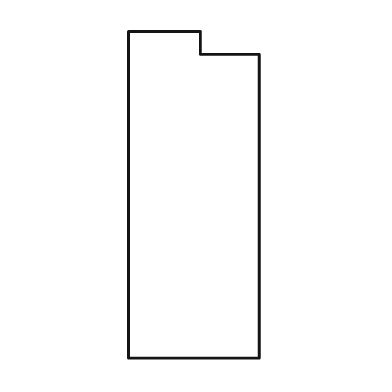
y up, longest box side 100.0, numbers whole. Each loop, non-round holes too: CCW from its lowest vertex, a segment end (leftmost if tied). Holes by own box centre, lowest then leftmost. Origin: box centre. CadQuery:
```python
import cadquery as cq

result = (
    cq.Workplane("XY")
    .moveTo(-20.0, -50.0)
    .lineTo(20.0, -50.0)
    .lineTo(20.0, 43.0)
    .lineTo(2.0, 43.0)
    .lineTo(2.0, 50.0)
    .lineTo(-20.0, 50.0)
    .close()
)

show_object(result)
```